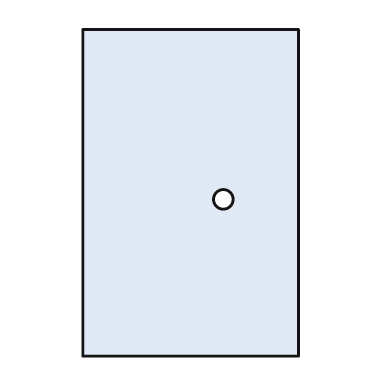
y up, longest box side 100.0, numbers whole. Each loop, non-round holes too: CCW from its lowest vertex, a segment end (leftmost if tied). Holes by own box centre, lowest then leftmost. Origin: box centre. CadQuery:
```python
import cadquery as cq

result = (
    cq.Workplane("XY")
    .moveTo(-33.0, -50.0)
    .lineTo(33.0, -50.0)
    .lineTo(33.0, 50.0)
    .lineTo(-33.0, 50.0)
    .close()
    .moveTo(10.0, -2.0)
    .circle(3.0)
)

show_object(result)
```